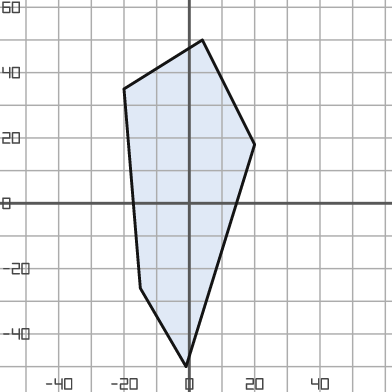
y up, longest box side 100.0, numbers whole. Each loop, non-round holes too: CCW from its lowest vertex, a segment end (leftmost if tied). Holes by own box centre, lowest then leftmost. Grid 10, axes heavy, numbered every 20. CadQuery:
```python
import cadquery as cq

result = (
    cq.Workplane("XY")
    .moveTo(-1.0, -50.0)
    .lineTo(20.0, 18.0)
    .lineTo(4.0, 50.0)
    .lineTo(-20.0, 35.0)
    .lineTo(-15.0, -26.0)
    .close()
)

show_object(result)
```